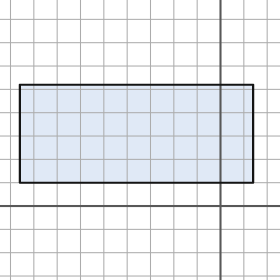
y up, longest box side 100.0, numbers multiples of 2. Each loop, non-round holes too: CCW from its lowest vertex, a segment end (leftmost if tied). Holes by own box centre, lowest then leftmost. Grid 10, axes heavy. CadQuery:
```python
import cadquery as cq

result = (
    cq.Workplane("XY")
    .moveTo(-86.0, 10.0)
    .lineTo(14.0, 10.0)
    .lineTo(14.0, 52.0)
    .lineTo(-86.0, 52.0)
    .close()
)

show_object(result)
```